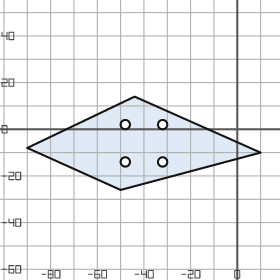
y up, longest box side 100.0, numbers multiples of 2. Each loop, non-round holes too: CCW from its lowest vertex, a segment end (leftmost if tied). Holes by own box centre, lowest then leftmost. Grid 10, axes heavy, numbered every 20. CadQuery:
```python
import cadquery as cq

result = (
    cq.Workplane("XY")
    .moveTo(-50.0, -26.0)
    .lineTo(10.0, -10.0)
    .lineTo(-44.0, 14.0)
    .lineTo(-90.0, -8.0)
    .close()
    .moveTo(-48.0, -14.0)
    .circle(2.0)
    .moveTo(-32.0, -14.0)
    .circle(2.0)
    .moveTo(-48.0, 2.0)
    .circle(2.0)
    .moveTo(-32.0, 2.0)
    .circle(2.0)
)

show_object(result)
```